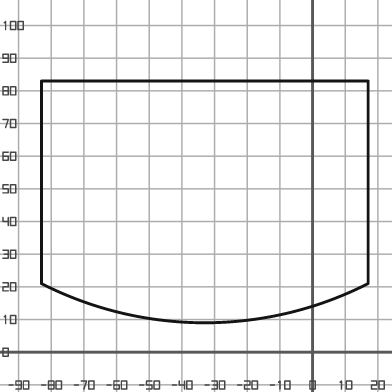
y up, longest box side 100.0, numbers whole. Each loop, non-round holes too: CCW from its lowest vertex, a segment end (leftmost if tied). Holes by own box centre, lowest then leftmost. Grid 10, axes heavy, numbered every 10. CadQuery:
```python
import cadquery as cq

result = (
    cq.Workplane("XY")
    .moveTo(-83.0, 21.0)
    .threePointArc((-33.0, 9.0), (17.0, 21.0))
    .lineTo(17.0, 83.0)
    .lineTo(-83.0, 83.0)
    .close()
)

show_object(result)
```